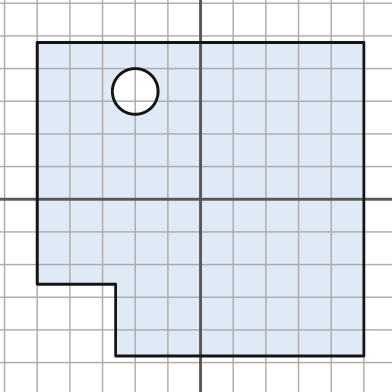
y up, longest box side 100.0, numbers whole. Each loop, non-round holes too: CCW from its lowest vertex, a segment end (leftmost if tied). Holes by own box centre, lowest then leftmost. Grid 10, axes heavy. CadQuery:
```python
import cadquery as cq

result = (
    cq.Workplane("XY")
    .moveTo(-26.0, -48.0)
    .lineTo(50.0, -48.0)
    .lineTo(50.0, 48.0)
    .lineTo(-50.0, 48.0)
    .lineTo(-50.0, -26.0)
    .lineTo(-26.0, -26.0)
    .close()
    .moveTo(-20.0, 33.0)
    .circle(7.0)
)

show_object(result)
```